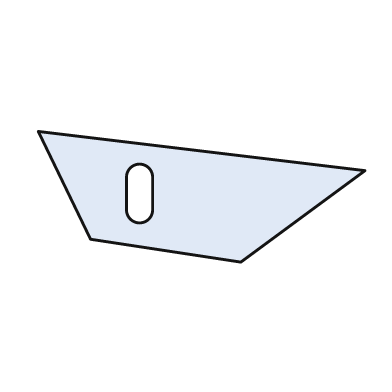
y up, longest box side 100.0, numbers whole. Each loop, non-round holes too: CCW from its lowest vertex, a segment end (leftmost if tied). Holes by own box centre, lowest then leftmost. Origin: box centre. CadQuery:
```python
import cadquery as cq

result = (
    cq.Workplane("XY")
    .moveTo(12.0, -20.0)
    .lineTo(50.0, 8.0)
    .lineTo(-50.0, 20.0)
    .lineTo(-34.0, -13.0)
    .close()
    .moveTo(-23.0, -4.0)
    .threePointArc((-19.0, -8.0), (-15.0, -4.0))
    .lineTo(-15.0, 6.0)
    .threePointArc((-19.0, 10.0), (-23.0, 6.0))
    .close()
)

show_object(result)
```